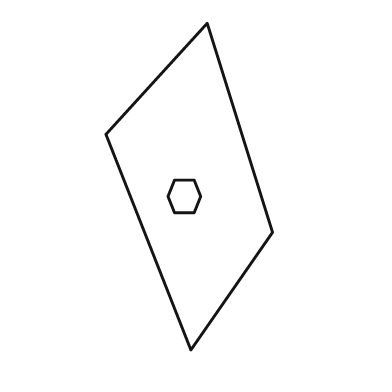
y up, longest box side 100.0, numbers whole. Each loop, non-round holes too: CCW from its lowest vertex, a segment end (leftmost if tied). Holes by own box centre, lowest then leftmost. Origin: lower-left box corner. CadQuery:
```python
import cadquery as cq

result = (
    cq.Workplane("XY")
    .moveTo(26.0, 0.0)
    .lineTo(51.0, 36.0)
    .lineTo(31.0, 100.0)
    .lineTo(0.0, 66.0)
    .close()
    .moveTo(21.0, 42.0)
    .lineTo(27.0, 42.0)
    .lineTo(29.0, 47.0)
    .lineTo(27.0, 52.0)
    .lineTo(21.0, 52.0)
    .lineTo(19.0, 47.0)
    .close()
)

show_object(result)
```